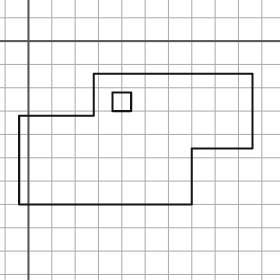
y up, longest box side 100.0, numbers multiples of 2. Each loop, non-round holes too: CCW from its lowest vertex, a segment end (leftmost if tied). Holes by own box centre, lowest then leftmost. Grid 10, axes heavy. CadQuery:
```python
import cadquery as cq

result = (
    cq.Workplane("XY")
    .moveTo(-4.0, -70.0)
    .lineTo(70.0, -70.0)
    .lineTo(70.0, -46.0)
    .lineTo(96.0, -46.0)
    .lineTo(96.0, -14.0)
    .lineTo(28.0, -14.0)
    .lineTo(28.0, -32.0)
    .lineTo(-4.0, -32.0)
    .close()
    .moveTo(36.0, -30.0)
    .lineTo(44.0, -30.0)
    .lineTo(44.0, -22.0)
    .lineTo(36.0, -22.0)
    .close()
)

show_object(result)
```